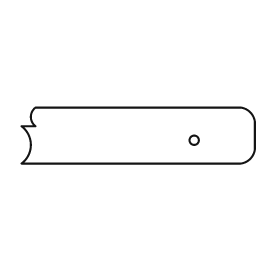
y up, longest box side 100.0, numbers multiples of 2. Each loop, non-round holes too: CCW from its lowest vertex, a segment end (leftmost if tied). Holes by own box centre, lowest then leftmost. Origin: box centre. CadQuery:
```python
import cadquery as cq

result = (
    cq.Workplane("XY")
    .moveTo(-50.0, -12.0)
    .lineTo(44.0, -12.0)
    .threePointArc((48.0, -10.0), (50.0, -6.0))
    .lineTo(50.0, 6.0)
    .threePointArc((48.0, 10.0), (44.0, 12.0))
    .lineTo(-44.0, 12.0)
    .threePointArc((-46.0, 8.0), (-44.0, 4.0))
    .lineTo(-50.0, 4.0)
    .threePointArc((-46.0, -4.0), (-50.0, -12.0))
    .close()
    .moveTo(24.0, -2.0)
    .circle(2.0)
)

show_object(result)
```